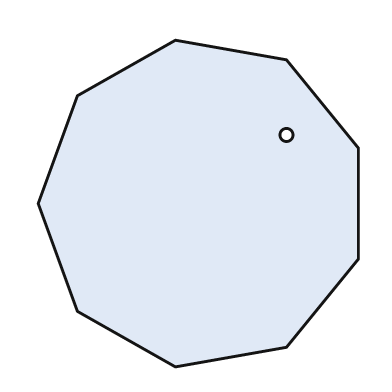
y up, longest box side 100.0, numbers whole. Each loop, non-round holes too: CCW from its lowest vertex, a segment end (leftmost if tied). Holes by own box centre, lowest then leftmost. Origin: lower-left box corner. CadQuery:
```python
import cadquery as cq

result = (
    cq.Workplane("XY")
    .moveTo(42.0, 0.0)
    .lineTo(76.0, 6.0)
    .lineTo(98.0, 33.0)
    .lineTo(98.0, 67.0)
    .lineTo(76.0, 94.0)
    .lineTo(42.0, 100.0)
    .lineTo(12.0, 83.0)
    .lineTo(0.0, 50.0)
    .lineTo(12.0, 17.0)
    .close()
    .moveTo(76.0, 71.0)
    .circle(2.0)
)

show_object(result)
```